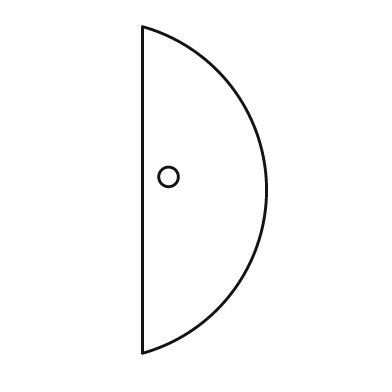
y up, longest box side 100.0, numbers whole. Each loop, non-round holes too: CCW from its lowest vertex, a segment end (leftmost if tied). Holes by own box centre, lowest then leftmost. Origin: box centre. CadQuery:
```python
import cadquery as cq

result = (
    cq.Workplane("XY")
    .moveTo(-19.0, -50.0)
    .threePointArc((19.0, 0.0), (-19.0, 50.0))
    .close()
    .moveTo(-11.0, 4.0)
    .circle(3.0)
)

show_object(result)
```